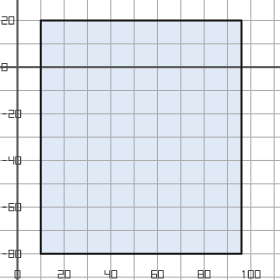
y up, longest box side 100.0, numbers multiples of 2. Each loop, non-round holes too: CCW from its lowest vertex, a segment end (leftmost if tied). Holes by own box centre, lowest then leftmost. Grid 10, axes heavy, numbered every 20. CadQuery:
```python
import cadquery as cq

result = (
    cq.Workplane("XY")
    .moveTo(10.0, -80.0)
    .lineTo(96.0, -80.0)
    .lineTo(96.0, 20.0)
    .lineTo(10.0, 20.0)
    .close()
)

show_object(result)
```